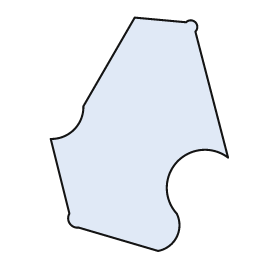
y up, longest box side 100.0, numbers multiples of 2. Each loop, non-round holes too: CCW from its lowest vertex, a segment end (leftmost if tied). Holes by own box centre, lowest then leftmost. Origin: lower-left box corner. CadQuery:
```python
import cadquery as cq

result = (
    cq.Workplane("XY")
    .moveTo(46.0, 0.0)
    .threePointArc((54.0, 6.0), (54.0, 16.0))
    .threePointArc((54.0, 38.0), (76.0, 40.0))
    .lineTo(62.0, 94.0)
    .threePointArc((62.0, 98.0), (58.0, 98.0))
    .lineTo(36.0, 100.0)
    .lineTo(14.0, 62.0)
    .threePointArc((10.0, 52.0), (0.0, 48.0))
    .lineTo(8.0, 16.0)
    .threePointArc((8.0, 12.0), (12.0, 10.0))
    .close()
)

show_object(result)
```